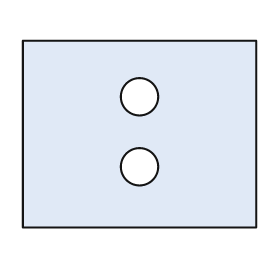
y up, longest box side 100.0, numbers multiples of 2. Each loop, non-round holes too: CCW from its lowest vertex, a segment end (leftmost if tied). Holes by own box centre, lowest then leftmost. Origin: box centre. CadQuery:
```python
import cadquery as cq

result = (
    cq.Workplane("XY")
    .moveTo(-50.0, -40.0)
    .lineTo(50.0, -40.0)
    .lineTo(50.0, 40.0)
    .lineTo(-50.0, 40.0)
    .close()
    .moveTo(0.0, -14.0)
    .circle(8.0)
    .moveTo(0.0, 16.0)
    .circle(8.0)
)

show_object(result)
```